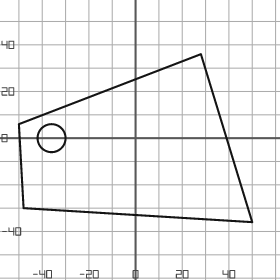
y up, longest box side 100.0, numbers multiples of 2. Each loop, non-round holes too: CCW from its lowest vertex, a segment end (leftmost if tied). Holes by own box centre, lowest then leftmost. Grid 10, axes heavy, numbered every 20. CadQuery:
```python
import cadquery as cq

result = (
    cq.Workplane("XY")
    .moveTo(50.0, -36.0)
    .lineTo(28.0, 36.0)
    .lineTo(-50.0, 6.0)
    .lineTo(-48.0, -30.0)
    .close()
    .moveTo(-36.0, 0.0)
    .circle(6.0)
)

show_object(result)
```